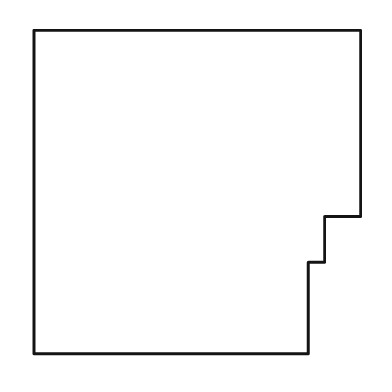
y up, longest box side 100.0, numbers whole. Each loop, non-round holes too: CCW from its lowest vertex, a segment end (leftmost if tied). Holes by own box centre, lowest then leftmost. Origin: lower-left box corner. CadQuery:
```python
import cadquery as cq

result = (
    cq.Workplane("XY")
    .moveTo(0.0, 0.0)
    .lineTo(84.0, 0.0)
    .lineTo(84.0, 28.0)
    .lineTo(89.0, 28.0)
    .lineTo(89.0, 42.0)
    .lineTo(100.0, 42.0)
    .lineTo(100.0, 99.0)
    .lineTo(0.0, 99.0)
    .close()
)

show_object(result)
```